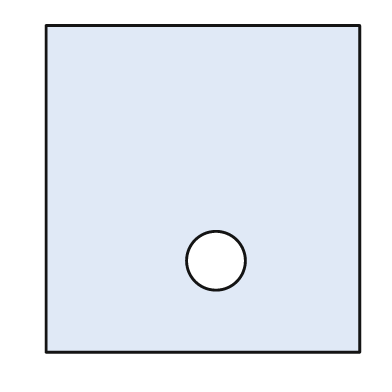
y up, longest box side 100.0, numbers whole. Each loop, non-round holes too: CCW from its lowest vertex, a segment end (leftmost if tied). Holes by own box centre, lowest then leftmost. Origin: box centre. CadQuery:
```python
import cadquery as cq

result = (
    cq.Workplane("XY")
    .moveTo(-48.0, -50.0)
    .lineTo(48.0, -50.0)
    .lineTo(48.0, 50.0)
    .lineTo(-48.0, 50.0)
    .close()
    .moveTo(4.0, -22.0)
    .circle(9.0)
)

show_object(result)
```